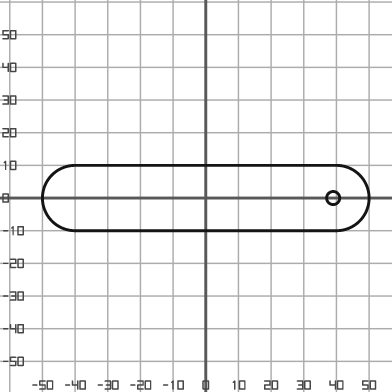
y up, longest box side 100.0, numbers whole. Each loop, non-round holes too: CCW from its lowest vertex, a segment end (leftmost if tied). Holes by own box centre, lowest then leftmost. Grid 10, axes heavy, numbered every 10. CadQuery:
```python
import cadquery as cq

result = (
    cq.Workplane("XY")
    .moveTo(-40.0, -10.0)
    .lineTo(40.0, -10.0)
    .threePointArc((50.0, 0.0), (40.0, 10.0))
    .lineTo(-40.0, 10.0)
    .threePointArc((-50.0, 0.0), (-40.0, -10.0))
    .close()
    .moveTo(39.0, 0.0)
    .circle(2.0)
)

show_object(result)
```